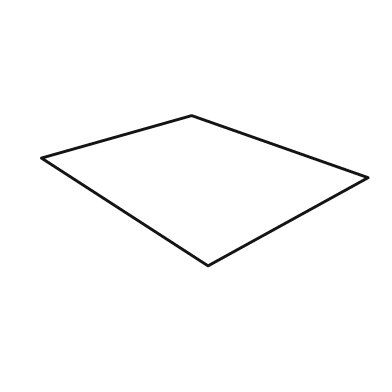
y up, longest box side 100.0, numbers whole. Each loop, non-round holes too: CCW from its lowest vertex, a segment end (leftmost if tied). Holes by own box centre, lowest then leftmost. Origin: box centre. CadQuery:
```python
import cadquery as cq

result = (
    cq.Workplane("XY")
    .moveTo(1.0, -23.0)
    .lineTo(50.0, 4.0)
    .lineTo(-4.0, 23.0)
    .lineTo(-50.0, 10.0)
    .close()
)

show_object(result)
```